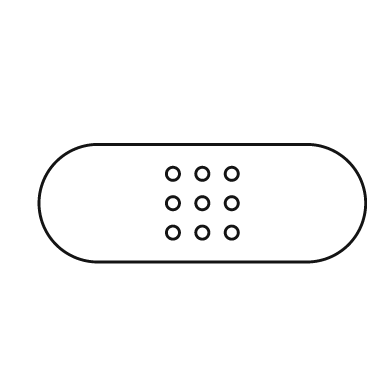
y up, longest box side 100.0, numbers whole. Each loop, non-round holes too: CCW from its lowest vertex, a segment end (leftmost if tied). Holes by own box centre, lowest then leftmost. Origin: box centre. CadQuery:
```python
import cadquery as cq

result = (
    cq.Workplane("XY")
    .moveTo(-32.0, -18.0)
    .lineTo(32.0, -18.0)
    .threePointArc((50.0, 0.0), (32.0, 18.0))
    .lineTo(-32.0, 18.0)
    .threePointArc((-50.0, 0.0), (-32.0, -18.0))
    .close()
    .moveTo(-9.0, -9.0)
    .circle(2.0)
    .moveTo(0.0, -9.0)
    .circle(2.0)
    .moveTo(9.0, -9.0)
    .circle(2.0)
    .moveTo(-9.0, 0.0)
    .circle(2.0)
    .moveTo(0.0, 0.0)
    .circle(2.0)
    .moveTo(9.0, 0.0)
    .circle(2.0)
    .moveTo(-9.0, 9.0)
    .circle(2.0)
    .moveTo(0.0, 9.0)
    .circle(2.0)
    .moveTo(9.0, 9.0)
    .circle(2.0)
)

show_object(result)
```